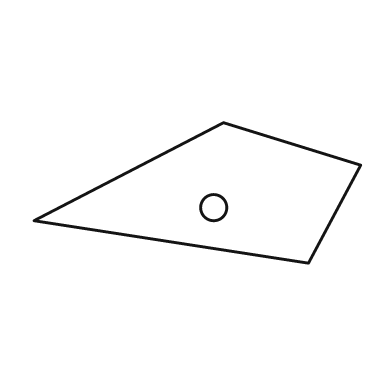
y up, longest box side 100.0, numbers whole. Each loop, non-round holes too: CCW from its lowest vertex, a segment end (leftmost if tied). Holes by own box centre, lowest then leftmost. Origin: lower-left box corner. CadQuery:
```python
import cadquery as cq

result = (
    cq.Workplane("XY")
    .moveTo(84.0, 0.0)
    .lineTo(100.0, 30.0)
    .lineTo(58.0, 43.0)
    .lineTo(0.0, 13.0)
    .close()
    .moveTo(55.0, 17.0)
    .circle(4.0)
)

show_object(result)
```